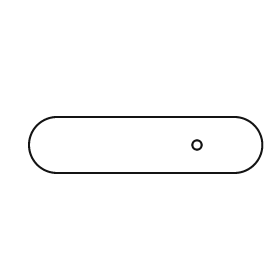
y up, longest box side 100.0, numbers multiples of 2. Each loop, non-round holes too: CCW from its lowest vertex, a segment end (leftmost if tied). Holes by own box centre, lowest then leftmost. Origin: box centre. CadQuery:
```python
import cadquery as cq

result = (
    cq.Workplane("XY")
    .moveTo(-38.0, -12.0)
    .lineTo(38.0, -12.0)
    .threePointArc((50.0, 0.0), (38.0, 12.0))
    .lineTo(-38.0, 12.0)
    .threePointArc((-50.0, 0.0), (-38.0, -12.0))
    .close()
    .moveTo(22.0, 0.0)
    .circle(2.0)
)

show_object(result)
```